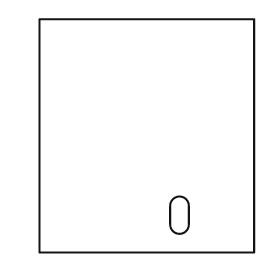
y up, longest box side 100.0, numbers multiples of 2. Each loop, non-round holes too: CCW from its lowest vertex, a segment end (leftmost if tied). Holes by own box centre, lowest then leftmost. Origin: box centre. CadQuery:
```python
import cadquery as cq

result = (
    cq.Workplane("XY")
    .moveTo(-46.0, -50.0)
    .lineTo(46.0, -50.0)
    .lineTo(46.0, 50.0)
    .lineTo(-46.0, 50.0)
    .close()
    .moveTo(10.0, -38.0)
    .threePointArc((14.0, -42.0), (18.0, -38.0))
    .lineTo(18.0, -30.0)
    .threePointArc((14.0, -26.0), (10.0, -30.0))
    .close()
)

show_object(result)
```